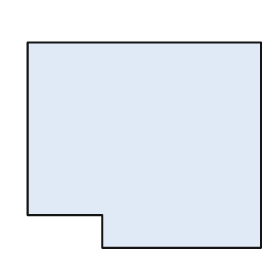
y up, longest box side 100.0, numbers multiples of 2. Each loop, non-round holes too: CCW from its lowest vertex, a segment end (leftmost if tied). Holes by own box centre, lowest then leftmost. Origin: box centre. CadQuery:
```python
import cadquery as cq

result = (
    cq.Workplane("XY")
    .moveTo(-18.0, -44.0)
    .lineTo(50.0, -44.0)
    .lineTo(50.0, 44.0)
    .lineTo(-50.0, 44.0)
    .lineTo(-50.0, -30.0)
    .lineTo(-18.0, -30.0)
    .close()
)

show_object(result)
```